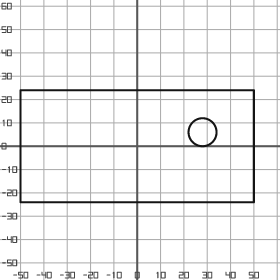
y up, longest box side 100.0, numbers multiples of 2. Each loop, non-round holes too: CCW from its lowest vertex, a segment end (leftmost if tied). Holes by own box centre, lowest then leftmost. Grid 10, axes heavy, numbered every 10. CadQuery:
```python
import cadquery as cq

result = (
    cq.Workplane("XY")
    .moveTo(-50.0, -24.0)
    .lineTo(50.0, -24.0)
    .lineTo(50.0, 24.0)
    .lineTo(-50.0, 24.0)
    .close()
    .moveTo(28.0, 6.0)
    .circle(6.0)
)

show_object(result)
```